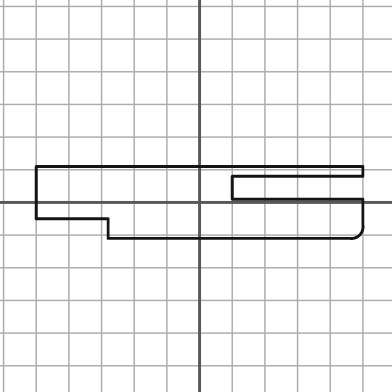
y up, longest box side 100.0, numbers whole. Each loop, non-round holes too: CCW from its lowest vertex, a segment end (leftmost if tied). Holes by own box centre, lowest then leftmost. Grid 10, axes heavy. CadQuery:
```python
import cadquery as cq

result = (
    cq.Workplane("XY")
    .moveTo(-28.0, -11.0)
    .lineTo(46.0, -11.0)
    .threePointArc((49.0, -10.0), (50.0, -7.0))
    .lineTo(50.0, 1.0)
    .lineTo(10.0, 1.0)
    .lineTo(10.0, 8.0)
    .lineTo(50.0, 8.0)
    .lineTo(50.0, 11.0)
    .lineTo(-50.0, 11.0)
    .lineTo(-50.0, -5.0)
    .lineTo(-28.0, -5.0)
    .close()
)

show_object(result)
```